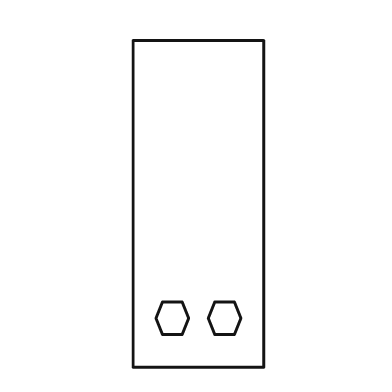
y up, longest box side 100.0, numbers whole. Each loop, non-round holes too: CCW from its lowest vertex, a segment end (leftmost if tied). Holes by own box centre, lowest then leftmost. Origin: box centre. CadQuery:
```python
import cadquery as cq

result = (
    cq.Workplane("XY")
    .moveTo(-20.0, -50.0)
    .lineTo(20.0, -50.0)
    .lineTo(20.0, 50.0)
    .lineTo(-20.0, 50.0)
    .close()
    .moveTo(-11.0, -40.0)
    .lineTo(-5.0, -40.0)
    .lineTo(-3.0, -35.0)
    .lineTo(-5.0, -30.0)
    .lineTo(-11.0, -30.0)
    .lineTo(-13.0, -35.0)
    .close()
    .moveTo(5.0, -40.0)
    .lineTo(11.0, -40.0)
    .lineTo(13.0, -35.0)
    .lineTo(11.0, -30.0)
    .lineTo(5.0, -30.0)
    .lineTo(3.0, -35.0)
    .close()
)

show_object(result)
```